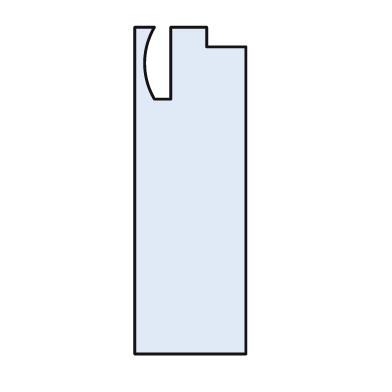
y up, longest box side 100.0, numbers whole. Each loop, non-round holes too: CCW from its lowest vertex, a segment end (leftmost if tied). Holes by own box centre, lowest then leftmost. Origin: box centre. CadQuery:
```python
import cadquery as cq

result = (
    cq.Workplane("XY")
    .moveTo(-17.0, -50.0)
    .lineTo(17.0, -50.0)
    .lineTo(17.0, 44.0)
    .lineTo(5.0, 44.0)
    .lineTo(5.0, 50.0)
    .lineTo(-6.0, 50.0)
    .lineTo(-6.0, 28.0)
    .lineTo(-11.0, 28.0)
    .threePointArc((-14.0, 39.0), (-11.0, 50.0))
    .lineTo(-17.0, 50.0)
    .close()
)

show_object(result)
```